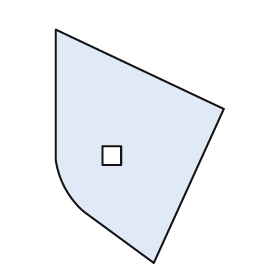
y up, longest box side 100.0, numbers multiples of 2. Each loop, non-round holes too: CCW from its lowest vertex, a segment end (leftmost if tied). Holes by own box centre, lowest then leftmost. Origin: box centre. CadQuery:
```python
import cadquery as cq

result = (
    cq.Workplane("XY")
    .moveTo(6.0, -50.0)
    .lineTo(36.0, 16.0)
    .lineTo(-36.0, 50.0)
    .lineTo(-36.0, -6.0)
    .threePointArc((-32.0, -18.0), (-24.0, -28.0))
    .close()
    .moveTo(-16.0, -8.0)
    .lineTo(-8.0, -8.0)
    .lineTo(-8.0, 0.0)
    .lineTo(-16.0, 0.0)
    .close()
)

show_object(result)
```